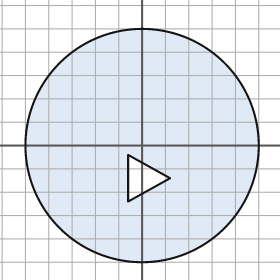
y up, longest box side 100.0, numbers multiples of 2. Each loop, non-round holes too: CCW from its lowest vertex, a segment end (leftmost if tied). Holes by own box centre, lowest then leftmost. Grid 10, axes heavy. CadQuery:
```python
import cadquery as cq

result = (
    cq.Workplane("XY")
    .moveTo(0.0, 0.0)
    .circle(50.0)
    .moveTo(-6.0, -24.0)
    .lineTo(12.0, -14.0)
    .lineTo(-6.0, -4.0)
    .close()
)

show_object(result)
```